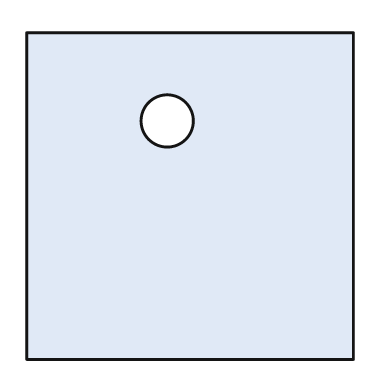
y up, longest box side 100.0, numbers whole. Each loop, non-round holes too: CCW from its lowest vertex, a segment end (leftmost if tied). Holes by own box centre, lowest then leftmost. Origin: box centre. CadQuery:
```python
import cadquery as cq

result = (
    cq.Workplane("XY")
    .moveTo(-50.0, -50.0)
    .lineTo(50.0, -50.0)
    .lineTo(50.0, 50.0)
    .lineTo(-50.0, 50.0)
    .close()
    .moveTo(-7.0, 23.0)
    .circle(8.0)
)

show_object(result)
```